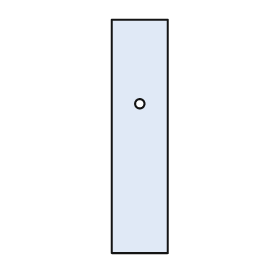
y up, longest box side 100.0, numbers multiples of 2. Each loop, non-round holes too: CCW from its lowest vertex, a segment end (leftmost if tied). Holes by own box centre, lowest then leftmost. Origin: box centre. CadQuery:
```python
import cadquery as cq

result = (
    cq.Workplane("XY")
    .moveTo(-12.0, -50.0)
    .lineTo(12.0, -50.0)
    .lineTo(12.0, 50.0)
    .lineTo(-12.0, 50.0)
    .close()
    .moveTo(0.0, 14.0)
    .circle(2.0)
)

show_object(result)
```